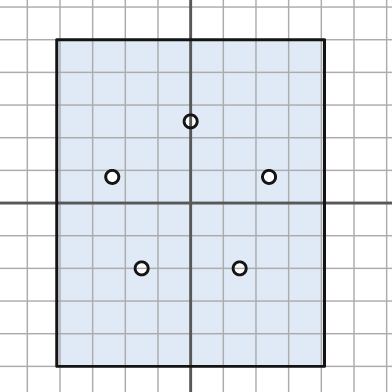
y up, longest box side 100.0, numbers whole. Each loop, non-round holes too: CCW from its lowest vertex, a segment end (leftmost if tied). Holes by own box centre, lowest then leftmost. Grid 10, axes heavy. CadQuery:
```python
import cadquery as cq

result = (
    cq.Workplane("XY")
    .moveTo(-41.0, -50.0)
    .lineTo(41.0, -50.0)
    .lineTo(41.0, 50.0)
    .lineTo(-41.0, 50.0)
    .close()
    .moveTo(-15.0, -20.0)
    .circle(2.0)
    .moveTo(15.0, -20.0)
    .circle(2.0)
    .moveTo(-24.0, 8.0)
    .circle(2.0)
    .moveTo(24.0, 8.0)
    .circle(2.0)
    .moveTo(0.0, 25.0)
    .circle(2.0)
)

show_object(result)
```